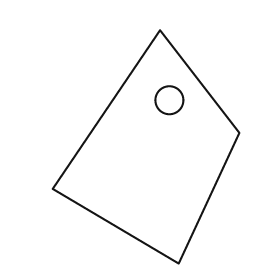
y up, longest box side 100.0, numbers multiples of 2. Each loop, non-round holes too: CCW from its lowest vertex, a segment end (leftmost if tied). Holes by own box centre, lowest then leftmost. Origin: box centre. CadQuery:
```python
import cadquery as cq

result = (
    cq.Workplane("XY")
    .moveTo(14.0, -50.0)
    .lineTo(40.0, 6.0)
    .lineTo(6.0, 50.0)
    .lineTo(-40.0, -18.0)
    .close()
    .moveTo(10.0, 20.0)
    .circle(6.0)
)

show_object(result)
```